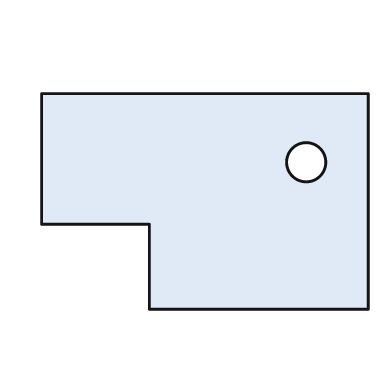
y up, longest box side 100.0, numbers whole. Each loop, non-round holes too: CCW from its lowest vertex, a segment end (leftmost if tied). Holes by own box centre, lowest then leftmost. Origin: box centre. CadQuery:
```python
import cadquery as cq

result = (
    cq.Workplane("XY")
    .moveTo(-17.0, -33.0)
    .lineTo(50.0, -33.0)
    .lineTo(50.0, 33.0)
    .lineTo(-50.0, 33.0)
    .lineTo(-50.0, -7.0)
    .lineTo(-17.0, -7.0)
    .close()
    .moveTo(31.0, 12.0)
    .circle(6.0)
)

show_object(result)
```